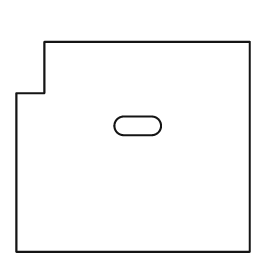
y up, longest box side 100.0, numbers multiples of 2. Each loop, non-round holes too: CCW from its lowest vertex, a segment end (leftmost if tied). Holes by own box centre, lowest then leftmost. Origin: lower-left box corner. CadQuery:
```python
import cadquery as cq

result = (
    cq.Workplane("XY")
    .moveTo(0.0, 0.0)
    .lineTo(100.0, 0.0)
    .lineTo(100.0, 90.0)
    .lineTo(12.0, 90.0)
    .lineTo(12.0, 68.0)
    .lineTo(0.0, 68.0)
    .close()
    .moveTo(46.0, 50.0)
    .lineTo(58.0, 50.0)
    .threePointArc((62.0, 54.0), (58.0, 58.0))
    .lineTo(46.0, 58.0)
    .threePointArc((42.0, 54.0), (46.0, 50.0))
    .close()
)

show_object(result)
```